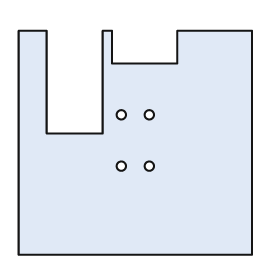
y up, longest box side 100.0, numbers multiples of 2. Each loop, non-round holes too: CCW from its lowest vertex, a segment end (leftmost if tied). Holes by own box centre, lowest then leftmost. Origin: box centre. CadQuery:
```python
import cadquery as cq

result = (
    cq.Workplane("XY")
    .moveTo(-50.0, -48.0)
    .lineTo(50.0, -48.0)
    .lineTo(50.0, 48.0)
    .lineTo(18.0, 48.0)
    .lineTo(18.0, 34.0)
    .lineTo(-10.0, 34.0)
    .lineTo(-10.0, 48.0)
    .lineTo(-14.0, 48.0)
    .lineTo(-14.0, 4.0)
    .lineTo(-38.0, 4.0)
    .lineTo(-38.0, 48.0)
    .lineTo(-50.0, 48.0)
    .close()
    .moveTo(-6.0, -10.0)
    .circle(2.0)
    .moveTo(6.0, -10.0)
    .circle(2.0)
    .moveTo(-6.0, 12.0)
    .circle(2.0)
    .moveTo(6.0, 12.0)
    .circle(2.0)
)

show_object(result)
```